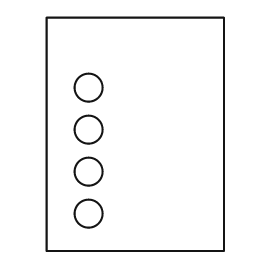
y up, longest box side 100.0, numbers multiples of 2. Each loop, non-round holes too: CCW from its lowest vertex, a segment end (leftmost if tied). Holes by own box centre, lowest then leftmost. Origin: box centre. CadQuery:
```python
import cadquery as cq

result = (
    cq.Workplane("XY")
    .moveTo(-38.0, -50.0)
    .lineTo(38.0, -50.0)
    .lineTo(38.0, 50.0)
    .lineTo(-38.0, 50.0)
    .close()
    .moveTo(-20.0, -34.0)
    .circle(6.0)
    .moveTo(-20.0, -16.0)
    .circle(6.0)
    .moveTo(-20.0, 2.0)
    .circle(6.0)
    .moveTo(-20.0, 20.0)
    .circle(6.0)
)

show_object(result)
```